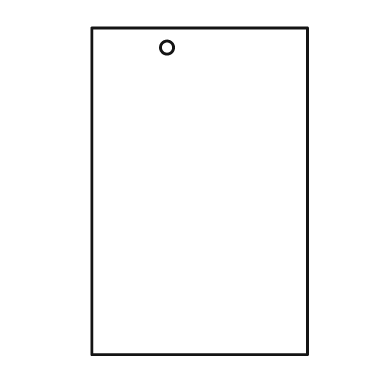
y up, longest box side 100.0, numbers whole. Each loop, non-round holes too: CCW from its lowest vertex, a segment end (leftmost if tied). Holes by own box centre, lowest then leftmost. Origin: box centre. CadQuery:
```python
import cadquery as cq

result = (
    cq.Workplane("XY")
    .moveTo(-33.0, -50.0)
    .lineTo(33.0, -50.0)
    .lineTo(33.0, 50.0)
    .lineTo(-33.0, 50.0)
    .close()
    .moveTo(-10.0, 44.0)
    .circle(2.0)
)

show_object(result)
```